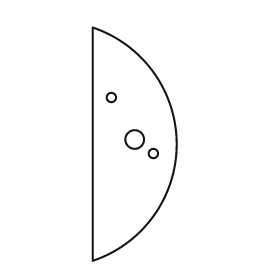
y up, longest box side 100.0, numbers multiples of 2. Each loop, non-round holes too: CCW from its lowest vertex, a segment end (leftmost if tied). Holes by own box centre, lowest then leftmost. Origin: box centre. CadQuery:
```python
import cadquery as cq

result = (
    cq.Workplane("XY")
    .moveTo(-18.0, -50.0)
    .threePointArc((18.0, 0.0), (-18.0, 50.0))
    .close()
    .moveTo(8.0, -4.0)
    .circle(2.0)
    .moveTo(0.0, 2.0)
    .circle(4.0)
    .moveTo(-10.0, 20.0)
    .circle(2.0)
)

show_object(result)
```